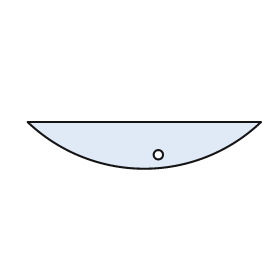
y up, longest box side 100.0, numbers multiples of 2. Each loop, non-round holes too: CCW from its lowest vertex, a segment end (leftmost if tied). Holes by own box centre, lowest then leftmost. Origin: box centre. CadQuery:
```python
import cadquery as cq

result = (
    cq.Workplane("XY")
    .moveTo(-50.0, 10.0)
    .threePointArc((0.0, -10.0), (50.0, 10.0))
    .close()
    .moveTo(6.0, -4.0)
    .circle(2.0)
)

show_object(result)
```